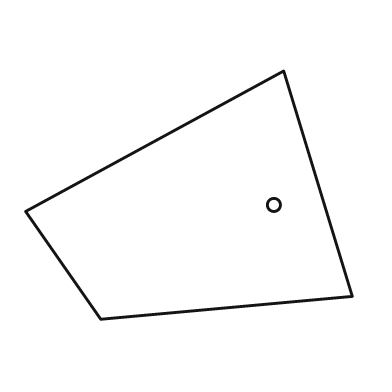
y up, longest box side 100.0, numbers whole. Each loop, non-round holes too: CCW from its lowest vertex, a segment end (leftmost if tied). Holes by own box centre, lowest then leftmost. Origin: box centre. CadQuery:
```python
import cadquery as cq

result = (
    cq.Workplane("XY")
    .moveTo(-27.0, -38.0)
    .lineTo(50.0, -31.0)
    .lineTo(29.0, 38.0)
    .lineTo(-50.0, -5.0)
    .close()
    .moveTo(26.0, -3.0)
    .circle(2.0)
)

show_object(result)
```